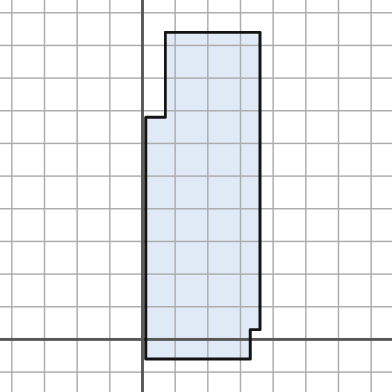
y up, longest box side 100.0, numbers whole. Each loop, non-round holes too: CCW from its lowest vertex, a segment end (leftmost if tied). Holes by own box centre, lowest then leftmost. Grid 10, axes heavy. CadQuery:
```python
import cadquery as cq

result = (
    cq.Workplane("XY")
    .moveTo(1.0, -6.0)
    .lineTo(33.0, -6.0)
    .lineTo(33.0, 3.0)
    .lineTo(36.0, 3.0)
    .lineTo(36.0, 94.0)
    .lineTo(7.0, 94.0)
    .lineTo(7.0, 68.0)
    .lineTo(1.0, 68.0)
    .close()
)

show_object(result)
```